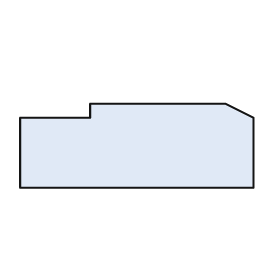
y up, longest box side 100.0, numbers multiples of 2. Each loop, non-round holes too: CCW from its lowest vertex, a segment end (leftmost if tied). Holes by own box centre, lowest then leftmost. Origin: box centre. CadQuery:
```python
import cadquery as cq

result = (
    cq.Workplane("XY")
    .moveTo(-50.0, -18.0)
    .lineTo(50.0, -18.0)
    .lineTo(50.0, 12.0)
    .lineTo(38.0, 18.0)
    .lineTo(-20.0, 18.0)
    .lineTo(-20.0, 12.0)
    .lineTo(-50.0, 12.0)
    .close()
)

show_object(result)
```